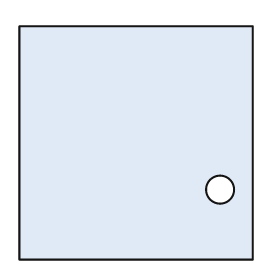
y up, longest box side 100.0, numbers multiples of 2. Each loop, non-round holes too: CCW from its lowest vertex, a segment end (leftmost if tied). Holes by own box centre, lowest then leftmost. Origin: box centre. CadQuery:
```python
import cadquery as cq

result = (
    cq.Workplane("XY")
    .moveTo(-50.0, -50.0)
    .lineTo(50.0, -50.0)
    .lineTo(50.0, 50.0)
    .lineTo(-50.0, 50.0)
    .close()
    .moveTo(36.0, -20.0)
    .circle(6.0)
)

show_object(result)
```